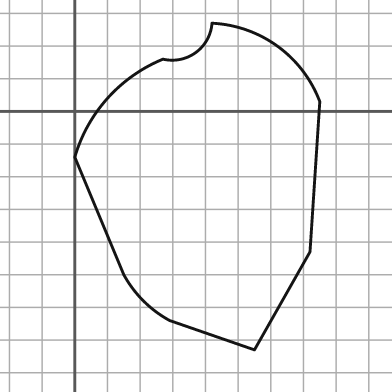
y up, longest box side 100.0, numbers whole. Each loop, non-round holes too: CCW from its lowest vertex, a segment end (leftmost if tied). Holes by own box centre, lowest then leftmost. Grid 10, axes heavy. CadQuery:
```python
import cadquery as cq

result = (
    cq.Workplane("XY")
    .moveTo(55.0, -73.0)
    .lineTo(72.0, -43.0)
    .lineTo(75.0, 3.0)
    .threePointArc((62.0, 20.0), (42.0, 27.0))
    .threePointArc((37.0, 18.0), (27.0, 16.0))
    .threePointArc((10.0, 4.0), (0.0, -14.0))
    .lineTo(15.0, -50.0)
    .threePointArc((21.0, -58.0), (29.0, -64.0))
    .close()
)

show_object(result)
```